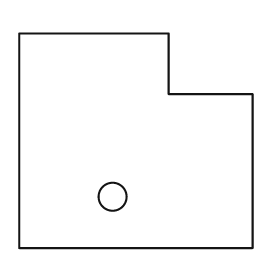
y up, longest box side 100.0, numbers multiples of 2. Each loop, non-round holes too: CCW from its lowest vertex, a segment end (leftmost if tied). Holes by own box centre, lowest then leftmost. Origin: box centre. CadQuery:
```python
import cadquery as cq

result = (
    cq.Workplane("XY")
    .moveTo(-50.0, -46.0)
    .lineTo(50.0, -46.0)
    .lineTo(50.0, 20.0)
    .lineTo(14.0, 20.0)
    .lineTo(14.0, 46.0)
    .lineTo(-50.0, 46.0)
    .close()
    .moveTo(-10.0, -24.0)
    .circle(6.0)
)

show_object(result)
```